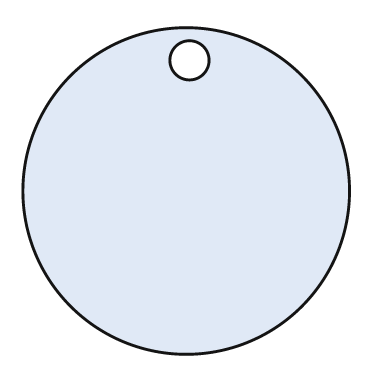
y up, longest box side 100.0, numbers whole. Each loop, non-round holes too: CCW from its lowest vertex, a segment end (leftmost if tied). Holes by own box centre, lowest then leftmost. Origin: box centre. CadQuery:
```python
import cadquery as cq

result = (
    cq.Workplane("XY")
    .moveTo(0.0, 0.0)
    .circle(50.0)
    .moveTo(1.0, 40.0)
    .circle(6.0)
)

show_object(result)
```